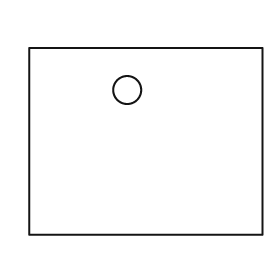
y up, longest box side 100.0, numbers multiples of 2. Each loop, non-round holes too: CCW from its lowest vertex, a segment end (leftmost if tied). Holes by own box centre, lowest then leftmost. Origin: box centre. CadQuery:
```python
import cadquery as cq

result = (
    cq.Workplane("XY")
    .moveTo(-50.0, -40.0)
    .lineTo(50.0, -40.0)
    .lineTo(50.0, 40.0)
    .lineTo(-50.0, 40.0)
    .close()
    .moveTo(-8.0, 22.0)
    .circle(6.0)
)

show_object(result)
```